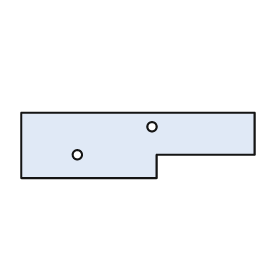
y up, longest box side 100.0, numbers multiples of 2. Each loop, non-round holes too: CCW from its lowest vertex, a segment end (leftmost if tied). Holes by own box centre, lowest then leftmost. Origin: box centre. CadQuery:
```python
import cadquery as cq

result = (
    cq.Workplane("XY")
    .moveTo(-50.0, -14.0)
    .lineTo(8.0, -14.0)
    .lineTo(8.0, -4.0)
    .lineTo(50.0, -4.0)
    .lineTo(50.0, 14.0)
    .lineTo(-50.0, 14.0)
    .close()
    .moveTo(-26.0, -4.0)
    .circle(2.0)
    .moveTo(6.0, 8.0)
    .circle(2.0)
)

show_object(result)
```